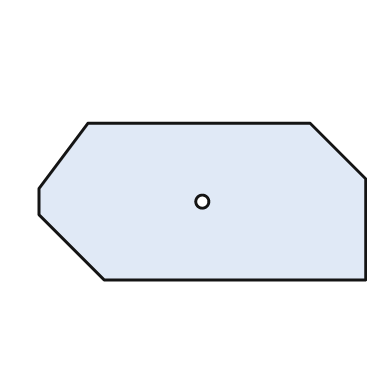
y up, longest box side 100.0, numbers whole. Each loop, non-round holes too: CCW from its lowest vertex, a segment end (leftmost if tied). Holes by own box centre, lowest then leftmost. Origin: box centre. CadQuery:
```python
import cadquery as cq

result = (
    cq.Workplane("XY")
    .moveTo(-30.0, -24.0)
    .lineTo(50.0, -24.0)
    .lineTo(50.0, 7.0)
    .lineTo(33.0, 24.0)
    .lineTo(-35.0, 24.0)
    .lineTo(-50.0, 4.0)
    .lineTo(-50.0, -4.0)
    .close()
    .moveTo(0.0, 0.0)
    .circle(2.0)
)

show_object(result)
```